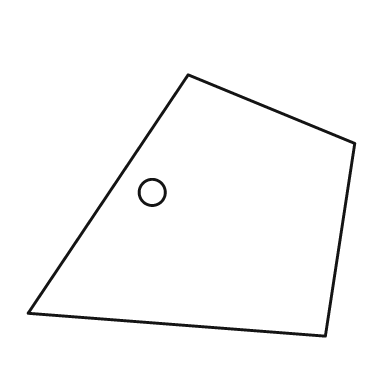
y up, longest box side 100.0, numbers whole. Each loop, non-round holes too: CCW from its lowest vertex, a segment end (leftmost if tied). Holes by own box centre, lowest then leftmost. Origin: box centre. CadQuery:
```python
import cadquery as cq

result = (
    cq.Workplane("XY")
    .moveTo(41.0, -40.0)
    .lineTo(50.0, 19.0)
    .lineTo(-1.0, 40.0)
    .lineTo(-50.0, -33.0)
    .close()
    .moveTo(-12.0, 4.0)
    .circle(4.0)
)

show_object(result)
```